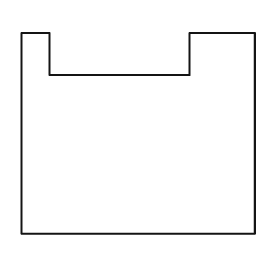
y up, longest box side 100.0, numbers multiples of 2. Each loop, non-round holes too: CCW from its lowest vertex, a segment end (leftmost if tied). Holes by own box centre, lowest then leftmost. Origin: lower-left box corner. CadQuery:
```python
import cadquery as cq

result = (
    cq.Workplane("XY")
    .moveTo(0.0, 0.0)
    .lineTo(100.0, 0.0)
    .lineTo(100.0, 86.0)
    .lineTo(72.0, 86.0)
    .lineTo(72.0, 68.0)
    .lineTo(12.0, 68.0)
    .lineTo(12.0, 86.0)
    .lineTo(0.0, 86.0)
    .close()
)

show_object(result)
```